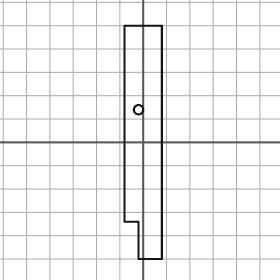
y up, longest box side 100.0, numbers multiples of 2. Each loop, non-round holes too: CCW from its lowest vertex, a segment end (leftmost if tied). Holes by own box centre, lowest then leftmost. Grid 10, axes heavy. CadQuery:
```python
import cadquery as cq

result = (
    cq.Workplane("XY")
    .moveTo(-2.0, -50.0)
    .lineTo(8.0, -50.0)
    .lineTo(8.0, 50.0)
    .lineTo(-8.0, 50.0)
    .lineTo(-8.0, -34.0)
    .lineTo(-2.0, -34.0)
    .close()
    .moveTo(-2.0, 14.0)
    .circle(2.0)
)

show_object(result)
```